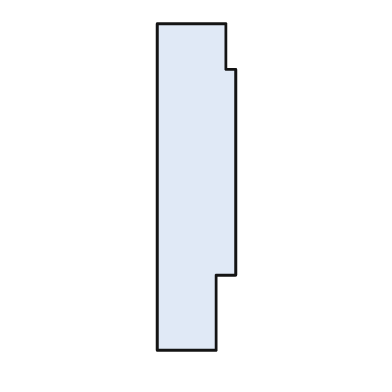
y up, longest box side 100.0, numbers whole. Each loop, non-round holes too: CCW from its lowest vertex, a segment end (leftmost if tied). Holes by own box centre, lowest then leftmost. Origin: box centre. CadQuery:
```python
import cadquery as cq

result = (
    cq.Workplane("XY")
    .moveTo(-12.0, -50.0)
    .lineTo(6.0, -50.0)
    .lineTo(6.0, -27.0)
    .lineTo(12.0, -27.0)
    .lineTo(12.0, 36.0)
    .lineTo(9.0, 36.0)
    .lineTo(9.0, 50.0)
    .lineTo(-12.0, 50.0)
    .close()
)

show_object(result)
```